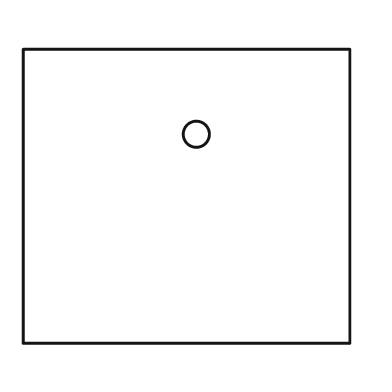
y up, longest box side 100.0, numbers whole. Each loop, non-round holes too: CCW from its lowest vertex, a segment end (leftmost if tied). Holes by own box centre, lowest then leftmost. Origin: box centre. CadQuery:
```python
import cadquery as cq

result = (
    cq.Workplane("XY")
    .moveTo(-50.0, -45.0)
    .lineTo(50.0, -45.0)
    .lineTo(50.0, 45.0)
    .lineTo(-50.0, 45.0)
    .close()
    .moveTo(3.0, 19.0)
    .circle(4.0)
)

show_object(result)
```